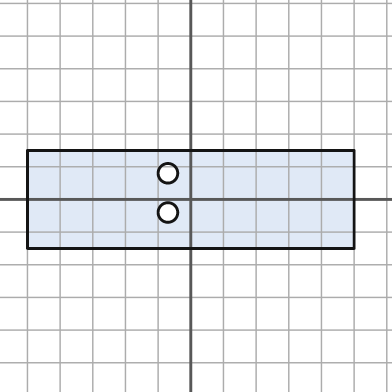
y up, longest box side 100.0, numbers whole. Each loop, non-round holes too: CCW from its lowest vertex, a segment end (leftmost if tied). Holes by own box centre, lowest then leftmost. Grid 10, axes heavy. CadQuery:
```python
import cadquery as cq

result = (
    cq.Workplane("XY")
    .moveTo(-50.0, -15.0)
    .lineTo(50.0, -15.0)
    .lineTo(50.0, 15.0)
    .lineTo(-50.0, 15.0)
    .close()
    .moveTo(-7.0, -4.0)
    .circle(3.0)
    .moveTo(-7.0, 8.0)
    .circle(3.0)
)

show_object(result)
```